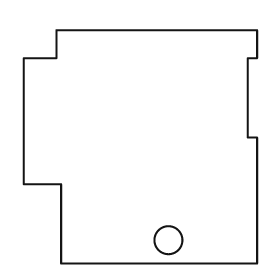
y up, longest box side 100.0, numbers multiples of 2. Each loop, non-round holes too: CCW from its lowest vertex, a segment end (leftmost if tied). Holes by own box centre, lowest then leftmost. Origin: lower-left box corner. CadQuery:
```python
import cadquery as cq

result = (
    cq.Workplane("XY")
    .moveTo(16.0, 0.0)
    .lineTo(100.0, 0.0)
    .lineTo(100.0, 54.0)
    .lineTo(96.0, 54.0)
    .lineTo(96.0, 88.0)
    .lineTo(100.0, 88.0)
    .lineTo(100.0, 100.0)
    .lineTo(14.0, 100.0)
    .lineTo(14.0, 88.0)
    .lineTo(0.0, 88.0)
    .lineTo(0.0, 34.0)
    .lineTo(16.0, 34.0)
    .close()
    .moveTo(62.0, 10.0)
    .circle(6.0)
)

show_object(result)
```